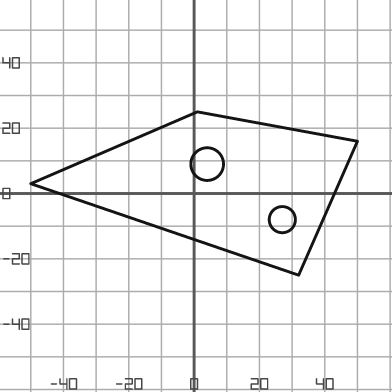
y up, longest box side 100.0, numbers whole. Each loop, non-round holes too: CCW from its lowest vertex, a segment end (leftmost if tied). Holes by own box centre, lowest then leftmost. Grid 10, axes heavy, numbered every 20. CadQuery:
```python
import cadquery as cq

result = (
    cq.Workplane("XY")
    .moveTo(32.0, -25.0)
    .lineTo(50.0, 16.0)
    .lineTo(1.0, 25.0)
    .lineTo(-50.0, 3.0)
    .close()
    .moveTo(27.0, -8.0)
    .circle(4.0)
    .moveTo(4.0, 9.0)
    .circle(5.0)
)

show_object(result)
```